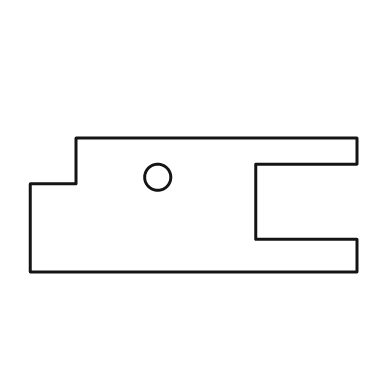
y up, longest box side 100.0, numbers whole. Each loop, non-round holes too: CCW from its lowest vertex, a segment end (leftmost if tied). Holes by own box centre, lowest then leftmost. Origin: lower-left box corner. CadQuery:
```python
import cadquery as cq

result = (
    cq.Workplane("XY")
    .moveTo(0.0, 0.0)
    .lineTo(100.0, 0.0)
    .lineTo(100.0, 10.0)
    .lineTo(69.0, 10.0)
    .lineTo(69.0, 33.0)
    .lineTo(100.0, 33.0)
    .lineTo(100.0, 41.0)
    .lineTo(14.0, 41.0)
    .lineTo(14.0, 27.0)
    .lineTo(0.0, 27.0)
    .close()
    .moveTo(39.0, 29.0)
    .circle(4.0)
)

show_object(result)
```